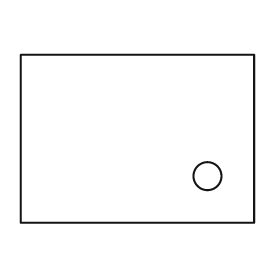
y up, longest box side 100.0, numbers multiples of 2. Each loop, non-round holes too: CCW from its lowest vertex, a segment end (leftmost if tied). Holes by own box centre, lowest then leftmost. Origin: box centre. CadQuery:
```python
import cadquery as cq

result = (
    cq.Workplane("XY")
    .moveTo(-50.0, -36.0)
    .lineTo(50.0, -36.0)
    .lineTo(50.0, 36.0)
    .lineTo(-50.0, 36.0)
    .close()
    .moveTo(30.0, -16.0)
    .circle(6.0)
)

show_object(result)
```